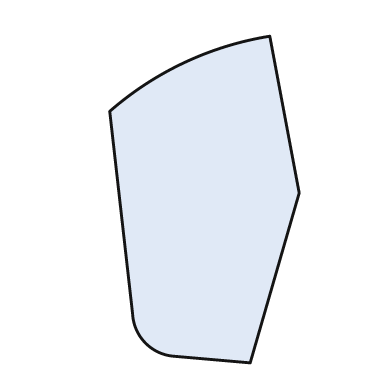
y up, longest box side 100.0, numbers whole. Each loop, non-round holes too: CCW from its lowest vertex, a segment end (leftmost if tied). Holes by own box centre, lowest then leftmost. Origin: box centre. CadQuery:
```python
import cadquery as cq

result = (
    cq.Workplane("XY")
    .moveTo(14.0, -50.0)
    .lineTo(29.0, 2.0)
    .lineTo(20.0, 50.0)
    .threePointArc((-6.0, 42.0), (-29.0, 27.0))
    .lineTo(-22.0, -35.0)
    .threePointArc((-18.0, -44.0), (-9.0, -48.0))
    .close()
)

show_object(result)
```